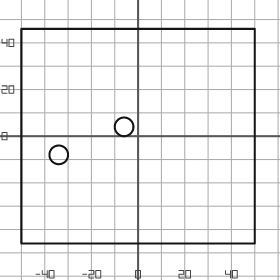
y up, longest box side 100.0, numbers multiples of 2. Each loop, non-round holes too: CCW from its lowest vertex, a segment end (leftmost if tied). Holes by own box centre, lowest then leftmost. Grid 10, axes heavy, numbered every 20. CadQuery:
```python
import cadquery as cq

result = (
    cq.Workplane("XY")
    .moveTo(-50.0, -46.0)
    .lineTo(50.0, -46.0)
    .lineTo(50.0, 46.0)
    .lineTo(-50.0, 46.0)
    .close()
    .moveTo(-34.0, -8.0)
    .circle(4.0)
    .moveTo(-6.0, 4.0)
    .circle(4.0)
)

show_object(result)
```